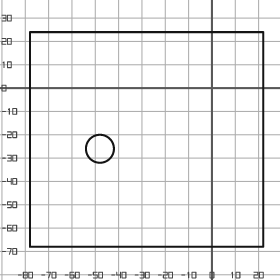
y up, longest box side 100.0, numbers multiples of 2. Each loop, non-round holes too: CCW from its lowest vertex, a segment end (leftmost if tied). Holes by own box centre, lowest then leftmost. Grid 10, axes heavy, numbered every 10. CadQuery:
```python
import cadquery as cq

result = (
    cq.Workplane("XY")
    .moveTo(-78.0, -68.0)
    .lineTo(22.0, -68.0)
    .lineTo(22.0, 24.0)
    .lineTo(-78.0, 24.0)
    .close()
    .moveTo(-48.0, -26.0)
    .circle(6.0)
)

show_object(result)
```